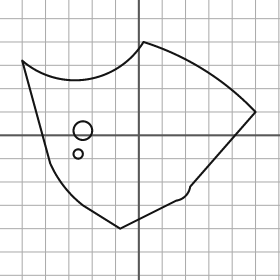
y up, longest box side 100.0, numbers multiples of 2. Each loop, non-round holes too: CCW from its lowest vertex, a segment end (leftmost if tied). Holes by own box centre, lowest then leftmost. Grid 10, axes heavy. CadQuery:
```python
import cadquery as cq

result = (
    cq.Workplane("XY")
    .moveTo(-8.0, -40.0)
    .lineTo(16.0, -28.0)
    .threePointArc((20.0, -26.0), (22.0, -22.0))
    .lineTo(50.0, 10.0)
    .threePointArc((28.0, 28.0), (2.0, 40.0))
    .threePointArc((-22.0, 24.0), (-50.0, 32.0))
    .lineTo(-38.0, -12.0)
    .threePointArc((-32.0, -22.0), (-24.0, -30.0))
    .close()
    .moveTo(-26.0, -8.0)
    .circle(2.0)
    .moveTo(-24.0, 2.0)
    .circle(4.0)
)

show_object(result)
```